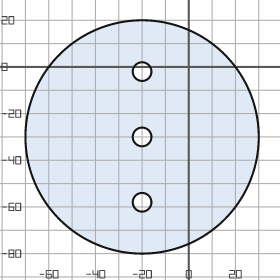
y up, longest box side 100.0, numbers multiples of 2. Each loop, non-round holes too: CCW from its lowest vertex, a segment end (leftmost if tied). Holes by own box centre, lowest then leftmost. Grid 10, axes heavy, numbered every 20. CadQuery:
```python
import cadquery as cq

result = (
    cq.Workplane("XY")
    .moveTo(-20.0, -30.0)
    .circle(50.0)
    .moveTo(-20.0, -58.0)
    .circle(4.0)
    .moveTo(-20.0, -30.0)
    .circle(4.0)
    .moveTo(-20.0, -2.0)
    .circle(4.0)
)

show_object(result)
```